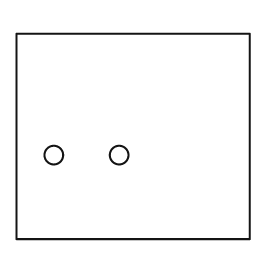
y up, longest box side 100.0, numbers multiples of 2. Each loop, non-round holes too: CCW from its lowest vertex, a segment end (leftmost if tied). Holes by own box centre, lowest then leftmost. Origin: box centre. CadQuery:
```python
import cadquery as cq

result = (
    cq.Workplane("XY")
    .moveTo(-50.0, -44.0)
    .lineTo(50.0, -44.0)
    .lineTo(50.0, 44.0)
    .lineTo(-50.0, 44.0)
    .close()
    .moveTo(-34.0, -8.0)
    .circle(4.0)
    .moveTo(-6.0, -8.0)
    .circle(4.0)
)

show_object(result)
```